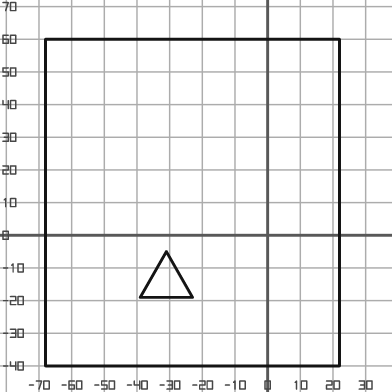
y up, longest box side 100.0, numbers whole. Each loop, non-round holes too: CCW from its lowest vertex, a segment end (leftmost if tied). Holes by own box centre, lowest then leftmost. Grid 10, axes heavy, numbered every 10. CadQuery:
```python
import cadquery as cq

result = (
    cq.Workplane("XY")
    .moveTo(-68.0, -40.0)
    .lineTo(22.0, -40.0)
    .lineTo(22.0, 60.0)
    .lineTo(-68.0, 60.0)
    .close()
    .moveTo(-39.0, -19.0)
    .lineTo(-23.0, -19.0)
    .lineTo(-31.0, -5.0)
    .close()
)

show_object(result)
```